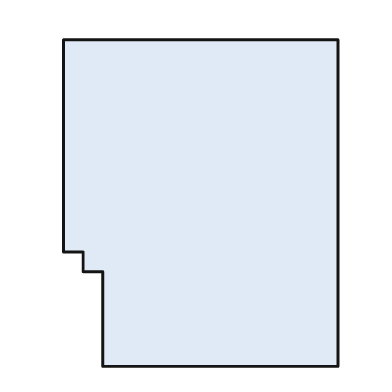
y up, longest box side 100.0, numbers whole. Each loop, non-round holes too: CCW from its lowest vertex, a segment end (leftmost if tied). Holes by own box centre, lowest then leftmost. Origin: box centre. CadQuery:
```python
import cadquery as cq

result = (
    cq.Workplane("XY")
    .moveTo(-30.0, -50.0)
    .lineTo(42.0, -50.0)
    .lineTo(42.0, 50.0)
    .lineTo(-42.0, 50.0)
    .lineTo(-42.0, -15.0)
    .lineTo(-36.0, -15.0)
    .lineTo(-36.0, -21.0)
    .lineTo(-30.0, -21.0)
    .close()
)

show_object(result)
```